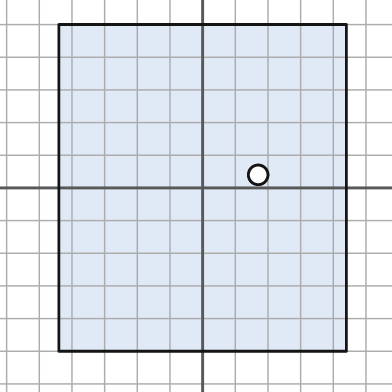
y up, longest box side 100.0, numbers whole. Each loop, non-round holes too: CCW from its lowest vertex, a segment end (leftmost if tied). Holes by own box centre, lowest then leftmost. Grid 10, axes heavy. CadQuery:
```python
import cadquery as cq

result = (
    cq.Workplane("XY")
    .moveTo(-44.0, -50.0)
    .lineTo(44.0, -50.0)
    .lineTo(44.0, 50.0)
    .lineTo(-44.0, 50.0)
    .close()
    .moveTo(17.0, 4.0)
    .circle(3.0)
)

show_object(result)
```